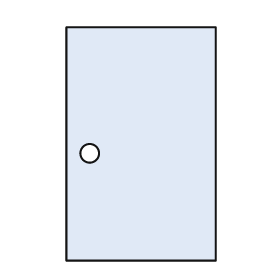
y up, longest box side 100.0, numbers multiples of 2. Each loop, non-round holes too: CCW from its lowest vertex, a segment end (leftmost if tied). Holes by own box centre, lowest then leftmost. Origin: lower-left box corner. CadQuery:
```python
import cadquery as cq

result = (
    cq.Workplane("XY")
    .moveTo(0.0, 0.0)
    .lineTo(64.0, 0.0)
    .lineTo(64.0, 100.0)
    .lineTo(0.0, 100.0)
    .close()
    .moveTo(10.0, 46.0)
    .circle(4.0)
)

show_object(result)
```